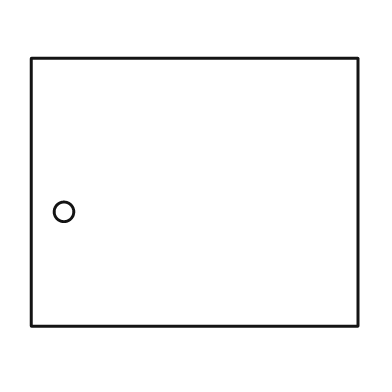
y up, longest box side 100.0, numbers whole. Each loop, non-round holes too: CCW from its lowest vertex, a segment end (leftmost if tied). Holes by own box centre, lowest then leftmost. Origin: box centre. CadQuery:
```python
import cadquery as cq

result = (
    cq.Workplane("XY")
    .moveTo(-50.0, -41.0)
    .lineTo(50.0, -41.0)
    .lineTo(50.0, 41.0)
    .lineTo(-50.0, 41.0)
    .close()
    .moveTo(-40.0, -6.0)
    .circle(3.0)
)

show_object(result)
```